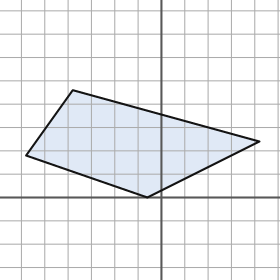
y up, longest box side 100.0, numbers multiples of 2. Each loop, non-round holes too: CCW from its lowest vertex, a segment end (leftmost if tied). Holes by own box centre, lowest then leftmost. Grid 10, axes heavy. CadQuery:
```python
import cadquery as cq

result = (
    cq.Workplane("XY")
    .moveTo(-6.0, 0.0)
    .lineTo(42.0, 24.0)
    .lineTo(-38.0, 46.0)
    .lineTo(-58.0, 18.0)
    .close()
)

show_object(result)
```